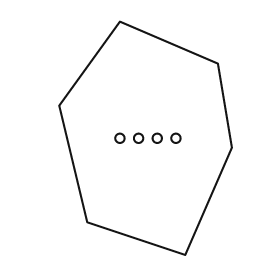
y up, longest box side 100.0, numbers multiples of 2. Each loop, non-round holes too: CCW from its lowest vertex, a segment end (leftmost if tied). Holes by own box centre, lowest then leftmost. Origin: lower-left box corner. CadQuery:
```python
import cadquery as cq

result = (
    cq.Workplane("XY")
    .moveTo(54.0, 0.0)
    .lineTo(74.0, 46.0)
    .lineTo(68.0, 82.0)
    .lineTo(26.0, 100.0)
    .lineTo(0.0, 64.0)
    .lineTo(12.0, 14.0)
    .close()
    .moveTo(26.0, 50.0)
    .circle(2.0)
    .moveTo(34.0, 50.0)
    .circle(2.0)
    .moveTo(42.0, 50.0)
    .circle(2.0)
    .moveTo(50.0, 50.0)
    .circle(2.0)
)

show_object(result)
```